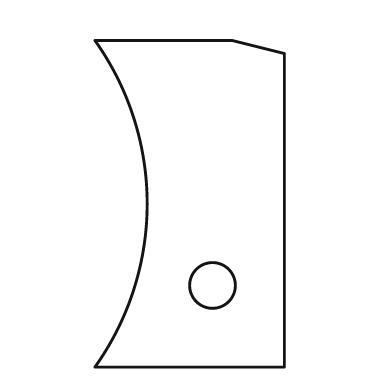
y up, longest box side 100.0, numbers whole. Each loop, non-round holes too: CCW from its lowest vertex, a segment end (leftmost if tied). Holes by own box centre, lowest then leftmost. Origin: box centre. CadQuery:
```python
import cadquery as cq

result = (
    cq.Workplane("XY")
    .moveTo(-29.0, -50.0)
    .lineTo(29.0, -50.0)
    .lineTo(29.0, 46.0)
    .lineTo(13.0, 50.0)
    .lineTo(-29.0, 50.0)
    .threePointArc((-13.0, 0.0), (-29.0, -50.0))
    .close()
    .moveTo(7.0, -25.0)
    .circle(7.0)
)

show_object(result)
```